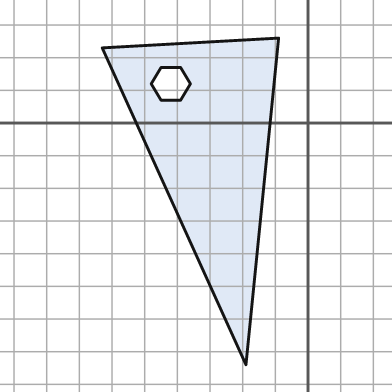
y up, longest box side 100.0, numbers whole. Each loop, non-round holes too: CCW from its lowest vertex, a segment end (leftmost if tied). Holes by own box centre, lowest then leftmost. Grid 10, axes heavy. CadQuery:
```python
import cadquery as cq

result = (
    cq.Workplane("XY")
    .moveTo(-19.0, -74.0)
    .lineTo(-9.0, 26.0)
    .lineTo(-63.0, 23.0)
    .close()
    .moveTo(-45.0, 7.0)
    .lineTo(-39.0, 7.0)
    .lineTo(-36.0, 12.0)
    .lineTo(-39.0, 17.0)
    .lineTo(-45.0, 17.0)
    .lineTo(-48.0, 12.0)
    .close()
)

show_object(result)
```